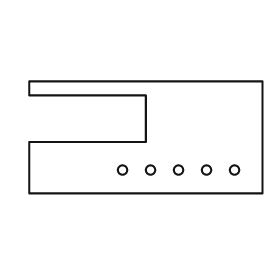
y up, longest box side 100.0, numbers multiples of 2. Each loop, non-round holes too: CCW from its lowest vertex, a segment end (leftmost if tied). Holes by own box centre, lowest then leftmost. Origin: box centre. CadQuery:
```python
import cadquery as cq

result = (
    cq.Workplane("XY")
    .moveTo(-50.0, -24.0)
    .lineTo(50.0, -24.0)
    .lineTo(50.0, 24.0)
    .lineTo(-50.0, 24.0)
    .lineTo(-50.0, 18.0)
    .lineTo(0.0, 18.0)
    .lineTo(0.0, -2.0)
    .lineTo(-50.0, -2.0)
    .close()
    .moveTo(-10.0, -14.0)
    .circle(2.0)
    .moveTo(2.0, -14.0)
    .circle(2.0)
    .moveTo(14.0, -14.0)
    .circle(2.0)
    .moveTo(26.0, -14.0)
    .circle(2.0)
    .moveTo(38.0, -14.0)
    .circle(2.0)
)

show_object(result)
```